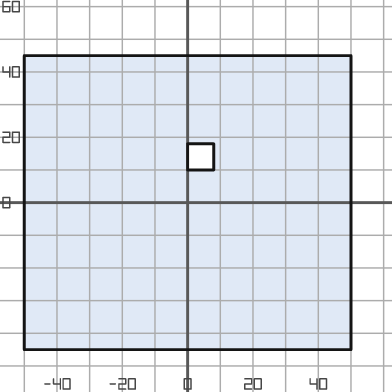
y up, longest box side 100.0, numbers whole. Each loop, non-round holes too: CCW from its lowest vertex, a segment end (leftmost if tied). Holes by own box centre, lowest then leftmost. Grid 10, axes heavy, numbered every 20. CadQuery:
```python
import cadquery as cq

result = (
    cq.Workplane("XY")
    .moveTo(-50.0, -45.0)
    .lineTo(50.0, -45.0)
    .lineTo(50.0, 45.0)
    .lineTo(-50.0, 45.0)
    .close()
    .moveTo(0.0, 10.0)
    .lineTo(8.0, 10.0)
    .lineTo(8.0, 18.0)
    .lineTo(0.0, 18.0)
    .close()
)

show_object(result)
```